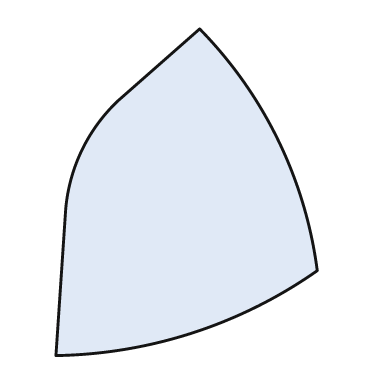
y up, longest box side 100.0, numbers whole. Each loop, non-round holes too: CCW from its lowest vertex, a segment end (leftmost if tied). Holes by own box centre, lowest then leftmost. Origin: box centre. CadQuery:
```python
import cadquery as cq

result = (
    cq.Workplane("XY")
    .moveTo(-40.0, -50.0)
    .threePointArc((2.0, -43.0), (40.0, -24.0))
    .threePointArc((28.0, 16.0), (4.0, 50.0))
    .lineTo(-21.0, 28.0)
    .threePointArc((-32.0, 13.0), (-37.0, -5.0))
    .close()
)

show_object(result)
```